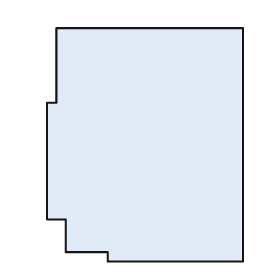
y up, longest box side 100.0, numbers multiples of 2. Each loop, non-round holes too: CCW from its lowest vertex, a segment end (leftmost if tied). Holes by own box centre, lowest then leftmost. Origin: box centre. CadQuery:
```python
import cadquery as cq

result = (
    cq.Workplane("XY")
    .moveTo(-16.0, -50.0)
    .lineTo(42.0, -50.0)
    .lineTo(42.0, 50.0)
    .lineTo(-38.0, 50.0)
    .lineTo(-38.0, 18.0)
    .lineTo(-42.0, 18.0)
    .lineTo(-42.0, -32.0)
    .lineTo(-34.0, -32.0)
    .lineTo(-34.0, -46.0)
    .lineTo(-16.0, -46.0)
    .close()
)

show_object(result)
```